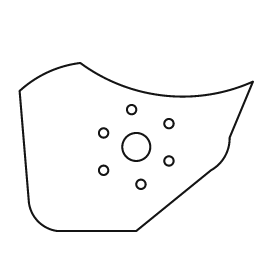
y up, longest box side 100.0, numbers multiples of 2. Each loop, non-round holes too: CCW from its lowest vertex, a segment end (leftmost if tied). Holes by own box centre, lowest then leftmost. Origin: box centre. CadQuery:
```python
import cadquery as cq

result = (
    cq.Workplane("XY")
    .moveTo(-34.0, -36.0)
    .lineTo(0.0, -36.0)
    .lineTo(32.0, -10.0)
    .threePointArc((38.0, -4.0), (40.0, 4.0))
    .lineTo(50.0, 28.0)
    .threePointArc((12.0, 22.0), (-24.0, 36.0))
    .threePointArc((-38.0, 32.0), (-50.0, 24.0))
    .lineTo(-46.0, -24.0)
    .threePointArc((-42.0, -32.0), (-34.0, -36.0))
    .close()
    .moveTo(2.0, -16.0)
    .circle(2.0)
    .moveTo(-14.0, -10.0)
    .circle(2.0)
    .moveTo(14.0, -6.0)
    .circle(2.0)
    .moveTo(0.0, 0.0)
    .circle(6.0)
    .moveTo(-14.0, 6.0)
    .circle(2.0)
    .moveTo(14.0, 10.0)
    .circle(2.0)
    .moveTo(-2.0, 16.0)
    .circle(2.0)
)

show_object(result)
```